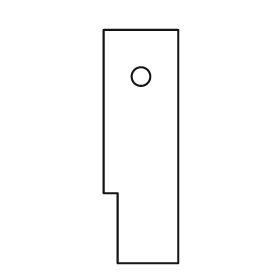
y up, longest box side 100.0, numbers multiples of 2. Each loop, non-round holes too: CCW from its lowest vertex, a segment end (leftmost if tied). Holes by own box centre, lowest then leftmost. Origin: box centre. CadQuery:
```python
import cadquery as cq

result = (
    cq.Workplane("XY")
    .moveTo(-10.0, -50.0)
    .lineTo(16.0, -50.0)
    .lineTo(16.0, 50.0)
    .lineTo(-16.0, 50.0)
    .lineTo(-16.0, -20.0)
    .lineTo(-10.0, -20.0)
    .close()
    .moveTo(0.0, 30.0)
    .circle(4.0)
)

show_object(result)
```